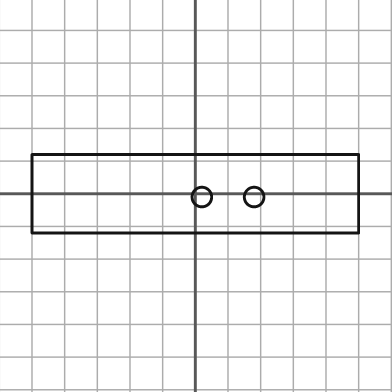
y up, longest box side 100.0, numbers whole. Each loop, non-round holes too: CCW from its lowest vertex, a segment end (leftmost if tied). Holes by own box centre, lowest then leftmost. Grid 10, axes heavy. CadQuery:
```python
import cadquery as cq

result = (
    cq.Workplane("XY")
    .moveTo(-50.0, -12.0)
    .lineTo(50.0, -12.0)
    .lineTo(50.0, 12.0)
    .lineTo(-50.0, 12.0)
    .close()
    .moveTo(2.0, -1.0)
    .circle(3.0)
    .moveTo(18.0, -1.0)
    .circle(3.0)
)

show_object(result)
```